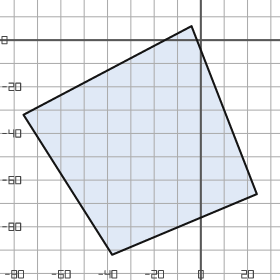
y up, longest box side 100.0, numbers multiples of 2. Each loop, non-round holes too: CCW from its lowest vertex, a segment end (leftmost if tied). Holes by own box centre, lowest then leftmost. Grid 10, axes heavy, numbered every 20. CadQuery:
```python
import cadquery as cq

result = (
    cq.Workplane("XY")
    .moveTo(-38.0, -92.0)
    .lineTo(24.0, -66.0)
    .lineTo(-4.0, 6.0)
    .lineTo(-76.0, -32.0)
    .close()
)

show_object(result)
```